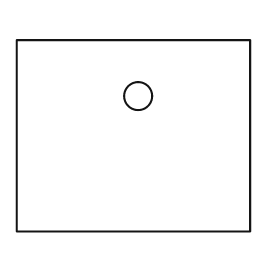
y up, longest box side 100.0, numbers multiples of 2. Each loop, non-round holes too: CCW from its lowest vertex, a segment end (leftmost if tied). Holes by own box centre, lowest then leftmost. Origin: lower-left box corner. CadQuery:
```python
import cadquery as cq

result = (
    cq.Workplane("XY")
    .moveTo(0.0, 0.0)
    .lineTo(100.0, 0.0)
    .lineTo(100.0, 82.0)
    .lineTo(0.0, 82.0)
    .close()
    .moveTo(52.0, 58.0)
    .circle(6.0)
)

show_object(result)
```